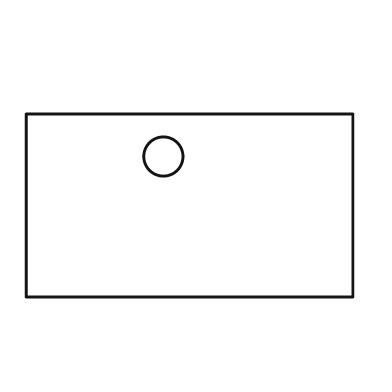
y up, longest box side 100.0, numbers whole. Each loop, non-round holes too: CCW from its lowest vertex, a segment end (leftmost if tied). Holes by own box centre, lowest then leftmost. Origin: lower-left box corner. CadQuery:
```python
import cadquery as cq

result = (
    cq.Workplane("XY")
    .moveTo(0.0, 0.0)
    .lineTo(100.0, 0.0)
    .lineTo(100.0, 56.0)
    .lineTo(0.0, 56.0)
    .close()
    .moveTo(42.0, 43.0)
    .circle(6.0)
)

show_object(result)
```